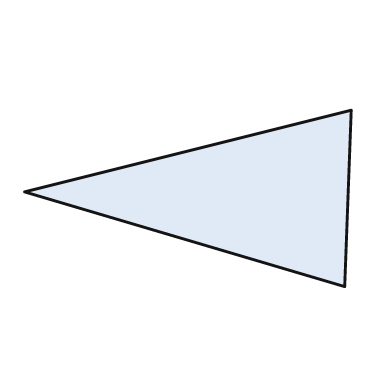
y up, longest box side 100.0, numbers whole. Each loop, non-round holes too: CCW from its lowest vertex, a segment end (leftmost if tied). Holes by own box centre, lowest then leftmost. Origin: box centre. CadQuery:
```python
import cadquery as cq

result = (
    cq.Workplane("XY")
    .moveTo(48.0, -27.0)
    .lineTo(50.0, 27.0)
    .lineTo(-50.0, 2.0)
    .close()
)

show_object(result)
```